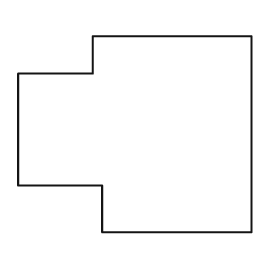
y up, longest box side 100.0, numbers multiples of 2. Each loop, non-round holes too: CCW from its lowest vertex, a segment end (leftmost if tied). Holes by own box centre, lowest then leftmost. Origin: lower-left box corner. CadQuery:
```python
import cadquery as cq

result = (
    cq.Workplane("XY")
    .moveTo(36.0, 0.0)
    .lineTo(100.0, 0.0)
    .lineTo(100.0, 84.0)
    .lineTo(32.0, 84.0)
    .lineTo(32.0, 68.0)
    .lineTo(0.0, 68.0)
    .lineTo(0.0, 20.0)
    .lineTo(36.0, 20.0)
    .close()
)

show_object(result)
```